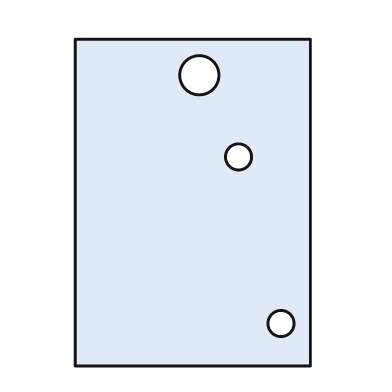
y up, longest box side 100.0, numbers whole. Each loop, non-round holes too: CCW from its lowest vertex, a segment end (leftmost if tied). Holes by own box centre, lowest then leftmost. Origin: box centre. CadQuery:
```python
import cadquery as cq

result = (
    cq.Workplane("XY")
    .moveTo(-36.0, -50.0)
    .lineTo(36.0, -50.0)
    .lineTo(36.0, 50.0)
    .lineTo(-36.0, 50.0)
    .close()
    .moveTo(27.0, -37.0)
    .circle(4.0)
    .moveTo(14.0, 14.0)
    .circle(4.0)
    .moveTo(2.0, 39.0)
    .circle(6.0)
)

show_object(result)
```